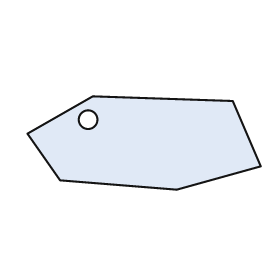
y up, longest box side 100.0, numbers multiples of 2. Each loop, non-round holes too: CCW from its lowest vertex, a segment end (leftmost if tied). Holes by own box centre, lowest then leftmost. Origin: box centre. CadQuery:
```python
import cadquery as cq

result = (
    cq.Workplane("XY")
    .moveTo(14.0, -20.0)
    .lineTo(50.0, -10.0)
    .lineTo(38.0, 18.0)
    .lineTo(-22.0, 20.0)
    .lineTo(-50.0, 4.0)
    .lineTo(-36.0, -16.0)
    .close()
    .moveTo(-24.0, 10.0)
    .circle(4.0)
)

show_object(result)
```